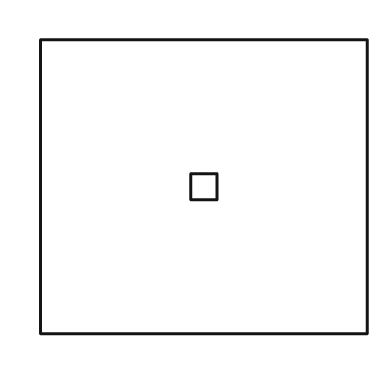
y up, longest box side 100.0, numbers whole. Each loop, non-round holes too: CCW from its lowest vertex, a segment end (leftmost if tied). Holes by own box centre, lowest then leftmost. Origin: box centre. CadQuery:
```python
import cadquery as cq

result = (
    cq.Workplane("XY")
    .moveTo(-50.0, -45.0)
    .lineTo(50.0, -45.0)
    .lineTo(50.0, 45.0)
    .lineTo(-50.0, 45.0)
    .close()
    .moveTo(-4.0, -4.0)
    .lineTo(4.0, -4.0)
    .lineTo(4.0, 4.0)
    .lineTo(-4.0, 4.0)
    .close()
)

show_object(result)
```